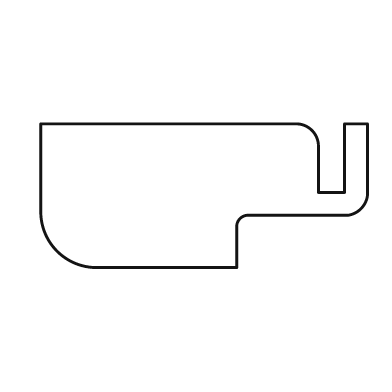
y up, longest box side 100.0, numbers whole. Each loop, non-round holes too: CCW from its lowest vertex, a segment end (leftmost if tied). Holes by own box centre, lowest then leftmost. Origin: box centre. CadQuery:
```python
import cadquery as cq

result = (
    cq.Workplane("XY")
    .moveTo(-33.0, -22.0)
    .lineTo(10.0, -22.0)
    .lineTo(10.0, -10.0)
    .threePointArc((11.0, -7.0), (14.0, -6.0))
    .lineTo(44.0, -6.0)
    .threePointArc((48.0, -4.0), (50.0, 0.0))
    .lineTo(50.0, 22.0)
    .lineTo(43.0, 22.0)
    .lineTo(43.0, 1.0)
    .lineTo(35.0, 1.0)
    .lineTo(35.0, 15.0)
    .threePointArc((33.0, 20.0), (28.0, 22.0))
    .lineTo(-50.0, 22.0)
    .lineTo(-50.0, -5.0)
    .threePointArc((-45.0, -17.0), (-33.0, -22.0))
    .close()
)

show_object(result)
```